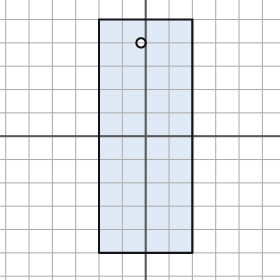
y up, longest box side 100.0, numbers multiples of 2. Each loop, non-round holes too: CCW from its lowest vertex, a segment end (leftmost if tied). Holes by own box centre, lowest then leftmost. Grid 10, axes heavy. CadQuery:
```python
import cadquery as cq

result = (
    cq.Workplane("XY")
    .moveTo(-20.0, -50.0)
    .lineTo(20.0, -50.0)
    .lineTo(20.0, 50.0)
    .lineTo(-20.0, 50.0)
    .close()
    .moveTo(-2.0, 40.0)
    .circle(2.0)
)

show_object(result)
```